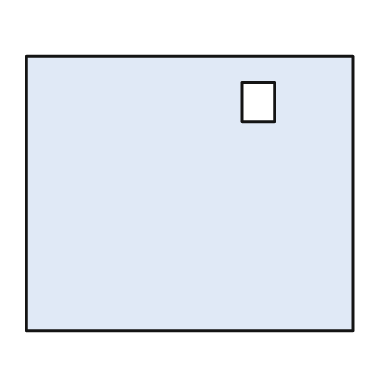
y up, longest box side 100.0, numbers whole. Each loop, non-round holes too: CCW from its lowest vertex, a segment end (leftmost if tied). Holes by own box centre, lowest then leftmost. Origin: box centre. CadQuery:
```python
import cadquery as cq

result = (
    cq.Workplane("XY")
    .moveTo(-50.0, -42.0)
    .lineTo(50.0, -42.0)
    .lineTo(50.0, 42.0)
    .lineTo(-50.0, 42.0)
    .close()
    .moveTo(16.0, 22.0)
    .lineTo(26.0, 22.0)
    .lineTo(26.0, 34.0)
    .lineTo(16.0, 34.0)
    .close()
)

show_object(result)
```